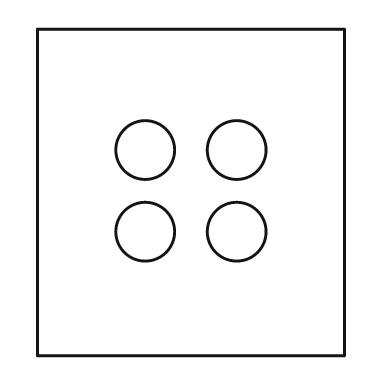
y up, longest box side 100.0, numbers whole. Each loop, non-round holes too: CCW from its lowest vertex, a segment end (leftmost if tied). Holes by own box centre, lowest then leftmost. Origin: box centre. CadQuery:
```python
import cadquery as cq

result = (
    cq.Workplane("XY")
    .moveTo(-47.0, -50.0)
    .lineTo(47.0, -50.0)
    .lineTo(47.0, 50.0)
    .lineTo(-47.0, 50.0)
    .close()
    .moveTo(-14.0, -12.0)
    .circle(9.0)
    .moveTo(14.0, -12.0)
    .circle(9.0)
    .moveTo(-14.0, 13.0)
    .circle(9.0)
    .moveTo(14.0, 13.0)
    .circle(9.0)
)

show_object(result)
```